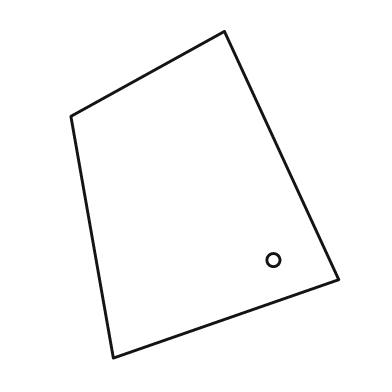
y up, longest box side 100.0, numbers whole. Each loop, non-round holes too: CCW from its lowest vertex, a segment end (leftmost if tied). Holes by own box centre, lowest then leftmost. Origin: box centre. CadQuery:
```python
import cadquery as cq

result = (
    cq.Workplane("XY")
    .moveTo(-28.0, -50.0)
    .lineTo(41.0, -26.0)
    .lineTo(6.0, 50.0)
    .lineTo(-41.0, 24.0)
    .close()
    .moveTo(21.0, -20.0)
    .circle(2.0)
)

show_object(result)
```